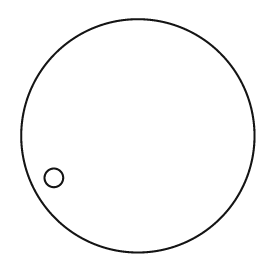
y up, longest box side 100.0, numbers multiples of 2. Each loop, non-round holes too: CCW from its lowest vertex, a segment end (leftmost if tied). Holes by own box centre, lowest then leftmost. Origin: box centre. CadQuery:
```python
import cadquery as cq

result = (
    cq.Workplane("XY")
    .moveTo(0.0, 0.0)
    .circle(50.0)
    .moveTo(-36.0, -18.0)
    .circle(4.0)
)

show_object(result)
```